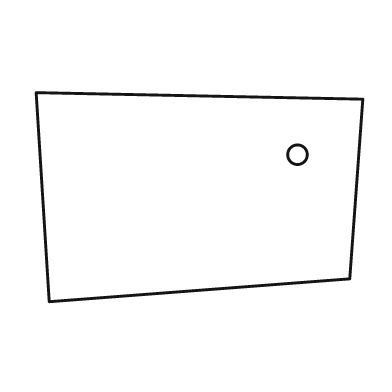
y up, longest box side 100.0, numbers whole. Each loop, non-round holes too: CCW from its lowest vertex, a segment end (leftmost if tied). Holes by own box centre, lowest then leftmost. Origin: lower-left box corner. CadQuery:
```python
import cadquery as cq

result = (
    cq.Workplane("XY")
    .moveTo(4.0, 0.0)
    .lineTo(96.0, 7.0)
    .lineTo(100.0, 62.0)
    .lineTo(0.0, 64.0)
    .close()
    .moveTo(80.0, 45.0)
    .circle(3.0)
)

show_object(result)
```